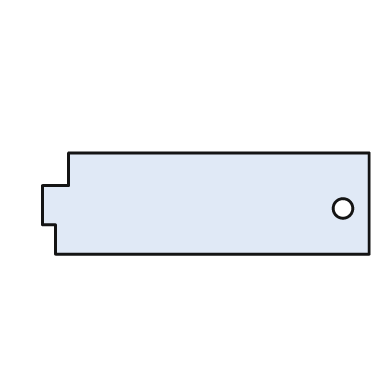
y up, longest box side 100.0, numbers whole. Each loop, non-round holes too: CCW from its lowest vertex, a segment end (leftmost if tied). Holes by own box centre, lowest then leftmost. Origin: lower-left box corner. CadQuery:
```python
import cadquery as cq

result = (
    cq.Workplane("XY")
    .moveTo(4.0, 0.0)
    .lineTo(100.0, 0.0)
    .lineTo(100.0, 31.0)
    .lineTo(8.0, 31.0)
    .lineTo(8.0, 21.0)
    .lineTo(0.0, 21.0)
    .lineTo(0.0, 9.0)
    .lineTo(4.0, 9.0)
    .close()
    .moveTo(92.0, 14.0)
    .circle(3.0)
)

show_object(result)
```